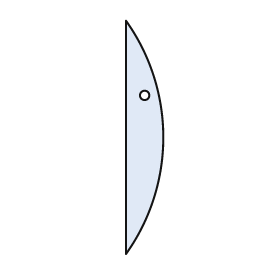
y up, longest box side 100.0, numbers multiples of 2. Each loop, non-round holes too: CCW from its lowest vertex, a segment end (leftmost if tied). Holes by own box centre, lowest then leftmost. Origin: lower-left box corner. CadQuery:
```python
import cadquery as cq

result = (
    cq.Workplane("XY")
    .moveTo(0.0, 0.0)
    .threePointArc((16.0, 50.0), (0.0, 100.0))
    .close()
    .moveTo(8.0, 68.0)
    .circle(2.0)
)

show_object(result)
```